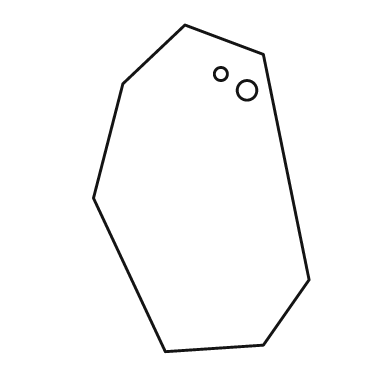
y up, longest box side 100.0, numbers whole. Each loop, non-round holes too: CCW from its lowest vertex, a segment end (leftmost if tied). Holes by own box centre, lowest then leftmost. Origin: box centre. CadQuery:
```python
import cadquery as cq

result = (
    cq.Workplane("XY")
    .moveTo(-11.0, -50.0)
    .lineTo(19.0, -48.0)
    .lineTo(33.0, -28.0)
    .lineTo(19.0, 41.0)
    .lineTo(-5.0, 50.0)
    .lineTo(-24.0, 32.0)
    .lineTo(-33.0, -3.0)
    .close()
    .moveTo(14.0, 30.0)
    .circle(3.0)
    .moveTo(6.0, 35.0)
    .circle(2.0)
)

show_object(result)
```